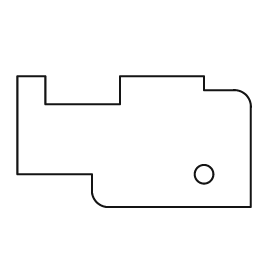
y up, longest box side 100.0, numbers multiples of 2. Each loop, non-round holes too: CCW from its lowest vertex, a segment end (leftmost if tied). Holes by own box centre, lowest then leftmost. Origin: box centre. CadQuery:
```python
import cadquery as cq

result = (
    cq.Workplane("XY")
    .moveTo(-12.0, -28.0)
    .lineTo(50.0, -28.0)
    .lineTo(50.0, 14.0)
    .threePointArc((48.0, 20.0), (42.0, 22.0))
    .lineTo(30.0, 22.0)
    .lineTo(30.0, 28.0)
    .lineTo(-6.0, 28.0)
    .lineTo(-6.0, 16.0)
    .lineTo(-38.0, 16.0)
    .lineTo(-38.0, 28.0)
    .lineTo(-50.0, 28.0)
    .lineTo(-50.0, -14.0)
    .lineTo(-18.0, -14.0)
    .lineTo(-18.0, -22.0)
    .threePointArc((-16.0, -26.0), (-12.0, -28.0))
    .close()
    .moveTo(30.0, -14.0)
    .circle(4.0)
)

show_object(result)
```